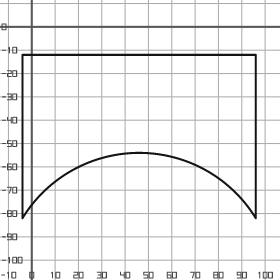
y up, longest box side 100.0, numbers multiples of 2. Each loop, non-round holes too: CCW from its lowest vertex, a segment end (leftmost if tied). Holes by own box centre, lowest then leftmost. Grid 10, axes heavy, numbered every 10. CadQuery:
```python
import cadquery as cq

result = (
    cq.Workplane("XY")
    .moveTo(-4.0, -82.0)
    .threePointArc((46.0, -54.0), (96.0, -82.0))
    .lineTo(96.0, -12.0)
    .lineTo(-4.0, -12.0)
    .close()
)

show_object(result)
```